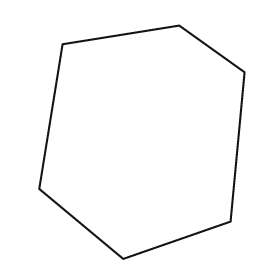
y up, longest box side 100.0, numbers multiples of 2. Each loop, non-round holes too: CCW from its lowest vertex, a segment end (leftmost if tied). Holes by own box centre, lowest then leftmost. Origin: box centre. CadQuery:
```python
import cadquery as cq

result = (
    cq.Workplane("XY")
    .moveTo(-8.0, -50.0)
    .lineTo(38.0, -34.0)
    .lineTo(44.0, 30.0)
    .lineTo(16.0, 50.0)
    .lineTo(-34.0, 42.0)
    .lineTo(-44.0, -20.0)
    .close()
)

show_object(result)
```